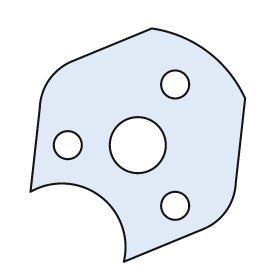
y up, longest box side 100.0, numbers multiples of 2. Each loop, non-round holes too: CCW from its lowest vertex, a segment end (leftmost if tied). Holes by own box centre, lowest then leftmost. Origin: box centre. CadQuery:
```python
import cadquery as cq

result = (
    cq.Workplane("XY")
    .moveTo(-6.0, -50.0)
    .lineTo(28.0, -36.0)
    .threePointArc((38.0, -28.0), (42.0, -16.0))
    .lineTo(46.0, 20.0)
    .threePointArc((30.0, 40.0), (6.0, 50.0))
    .lineTo(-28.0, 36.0)
    .threePointArc((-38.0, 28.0), (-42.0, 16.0))
    .lineTo(-46.0, -20.0)
    .threePointArc((-16.0, -22.0), (-6.0, -50.0))
    .close()
    .moveTo(16.0, -26.0)
    .circle(6.0)
    .moveTo(-30.0, 0.0)
    .circle(6.0)
    .moveTo(0.0, 0.0)
    .circle(12.0)
    .moveTo(16.0, 26.0)
    .circle(6.0)
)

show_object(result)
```